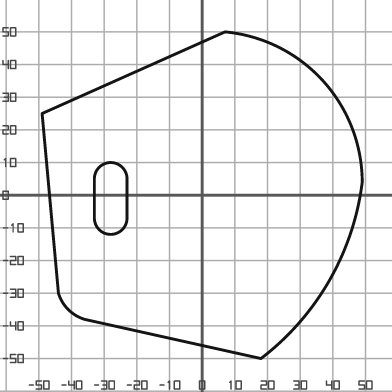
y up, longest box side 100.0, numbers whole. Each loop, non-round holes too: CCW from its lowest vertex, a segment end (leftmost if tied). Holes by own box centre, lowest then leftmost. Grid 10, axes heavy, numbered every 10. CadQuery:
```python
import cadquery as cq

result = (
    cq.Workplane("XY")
    .moveTo(18.0, -50.0)
    .threePointArc((39.0, -26.0), (49.0, 4.0))
    .threePointArc((37.0, 35.0), (7.0, 50.0))
    .lineTo(-49.0, 25.0)
    .lineTo(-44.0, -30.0)
    .threePointArc((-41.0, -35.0), (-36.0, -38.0))
    .close()
    .moveTo(-33.0, -7.0)
    .threePointArc((-28.0, -12.0), (-23.0, -7.0))
    .lineTo(-23.0, 5.0)
    .threePointArc((-28.0, 10.0), (-33.0, 5.0))
    .close()
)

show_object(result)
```